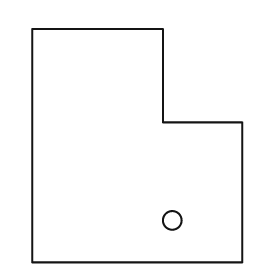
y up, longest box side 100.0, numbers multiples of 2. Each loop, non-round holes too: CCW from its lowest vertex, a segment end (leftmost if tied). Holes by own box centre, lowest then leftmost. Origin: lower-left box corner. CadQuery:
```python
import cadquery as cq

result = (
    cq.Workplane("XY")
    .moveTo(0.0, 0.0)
    .lineTo(90.0, 0.0)
    .lineTo(90.0, 60.0)
    .lineTo(56.0, 60.0)
    .lineTo(56.0, 100.0)
    .lineTo(0.0, 100.0)
    .close()
    .moveTo(60.0, 18.0)
    .circle(4.0)
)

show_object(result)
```